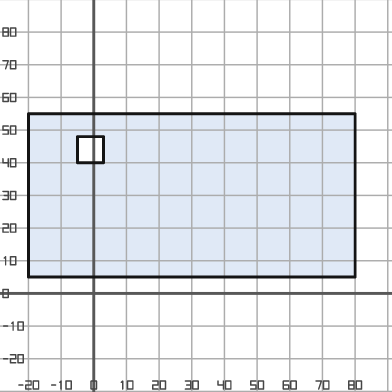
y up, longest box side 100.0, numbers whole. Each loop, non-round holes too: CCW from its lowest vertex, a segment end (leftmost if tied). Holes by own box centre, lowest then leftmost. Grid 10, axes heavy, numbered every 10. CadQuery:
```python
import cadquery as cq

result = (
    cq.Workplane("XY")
    .moveTo(-20.0, 5.0)
    .lineTo(80.0, 5.0)
    .lineTo(80.0, 55.0)
    .lineTo(-20.0, 55.0)
    .close()
    .moveTo(-5.0, 40.0)
    .lineTo(3.0, 40.0)
    .lineTo(3.0, 48.0)
    .lineTo(-5.0, 48.0)
    .close()
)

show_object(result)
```